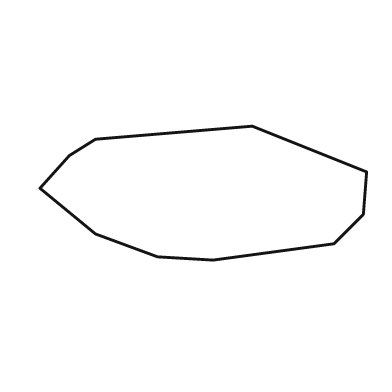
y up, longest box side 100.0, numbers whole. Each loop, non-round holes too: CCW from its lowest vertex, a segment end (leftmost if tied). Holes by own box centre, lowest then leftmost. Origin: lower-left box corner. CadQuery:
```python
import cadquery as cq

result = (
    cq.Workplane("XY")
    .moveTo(53.0, 0.0)
    .lineTo(90.0, 5.0)
    .lineTo(99.0, 14.0)
    .lineTo(100.0, 27.0)
    .lineTo(65.0, 41.0)
    .lineTo(17.0, 37.0)
    .lineTo(9.0, 32.0)
    .lineTo(0.0, 22.0)
    .lineTo(17.0, 8.0)
    .lineTo(36.0, 1.0)
    .close()
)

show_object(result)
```